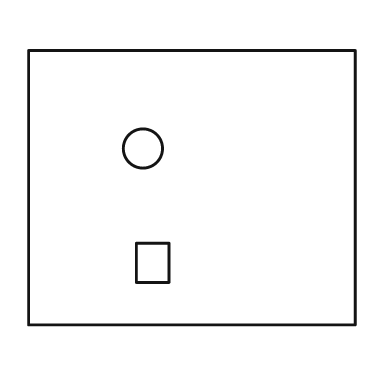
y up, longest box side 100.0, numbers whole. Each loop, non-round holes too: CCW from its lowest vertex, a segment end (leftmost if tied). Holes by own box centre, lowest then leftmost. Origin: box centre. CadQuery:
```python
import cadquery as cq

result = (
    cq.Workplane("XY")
    .moveTo(-50.0, -42.0)
    .lineTo(50.0, -42.0)
    .lineTo(50.0, 42.0)
    .lineTo(-50.0, 42.0)
    .close()
    .moveTo(-17.0, -29.0)
    .lineTo(-7.0, -29.0)
    .lineTo(-7.0, -17.0)
    .lineTo(-17.0, -17.0)
    .close()
    .moveTo(-15.0, 12.0)
    .circle(6.0)
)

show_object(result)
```